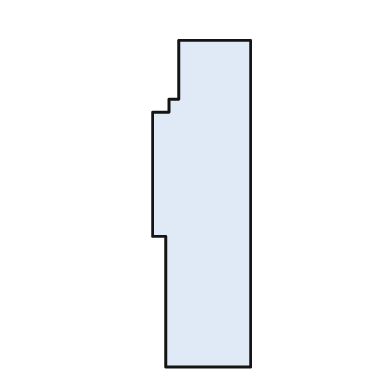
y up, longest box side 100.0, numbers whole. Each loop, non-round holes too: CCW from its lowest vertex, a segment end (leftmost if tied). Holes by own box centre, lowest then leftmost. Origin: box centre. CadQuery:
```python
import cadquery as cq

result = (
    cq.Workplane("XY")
    .moveTo(-11.0, -50.0)
    .lineTo(15.0, -50.0)
    .lineTo(15.0, 50.0)
    .lineTo(-7.0, 50.0)
    .lineTo(-7.0, 32.0)
    .lineTo(-10.0, 32.0)
    .lineTo(-10.0, 28.0)
    .lineTo(-15.0, 28.0)
    .lineTo(-15.0, -10.0)
    .lineTo(-11.0, -10.0)
    .close()
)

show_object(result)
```